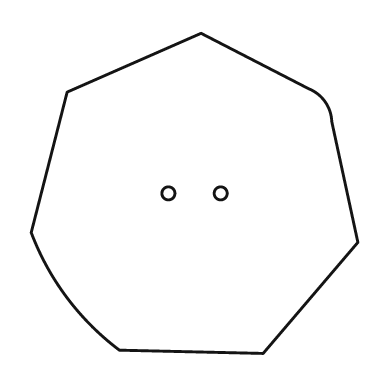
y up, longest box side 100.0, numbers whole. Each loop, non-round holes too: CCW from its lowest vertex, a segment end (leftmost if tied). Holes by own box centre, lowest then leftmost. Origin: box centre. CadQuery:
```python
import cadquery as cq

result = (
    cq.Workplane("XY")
    .moveTo(21.0, -49.0)
    .lineTo(50.0, -15.0)
    .lineTo(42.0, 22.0)
    .threePointArc((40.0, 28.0), (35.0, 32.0))
    .lineTo(2.0, 49.0)
    .lineTo(-39.0, 31.0)
    .lineTo(-50.0, -12.0)
    .threePointArc((-39.0, -32.0), (-23.0, -48.0))
    .close()
    .moveTo(-8.0, 0.0)
    .circle(2.0)
    .moveTo(8.0, 0.0)
    .circle(2.0)
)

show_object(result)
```